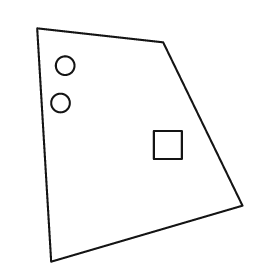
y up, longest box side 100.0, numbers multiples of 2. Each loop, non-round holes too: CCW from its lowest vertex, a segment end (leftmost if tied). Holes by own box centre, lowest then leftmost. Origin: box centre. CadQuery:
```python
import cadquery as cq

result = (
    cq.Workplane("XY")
    .moveTo(-38.0, -50.0)
    .lineTo(44.0, -26.0)
    .lineTo(10.0, 44.0)
    .lineTo(-44.0, 50.0)
    .close()
    .moveTo(6.0, -6.0)
    .lineTo(18.0, -6.0)
    .lineTo(18.0, 6.0)
    .lineTo(6.0, 6.0)
    .close()
    .moveTo(-34.0, 18.0)
    .circle(4.0)
    .moveTo(-32.0, 34.0)
    .circle(4.0)
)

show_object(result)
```